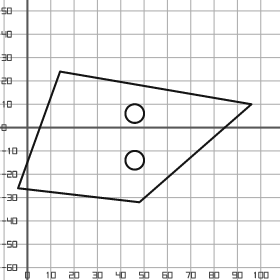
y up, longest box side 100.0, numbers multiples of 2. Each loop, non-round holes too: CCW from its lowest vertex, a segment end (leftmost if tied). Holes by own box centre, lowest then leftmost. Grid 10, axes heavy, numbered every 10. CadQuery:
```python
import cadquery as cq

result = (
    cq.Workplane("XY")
    .moveTo(48.0, -32.0)
    .lineTo(96.0, 10.0)
    .lineTo(14.0, 24.0)
    .lineTo(-4.0, -26.0)
    .close()
    .moveTo(46.0, -14.0)
    .circle(4.0)
    .moveTo(46.0, 6.0)
    .circle(4.0)
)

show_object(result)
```